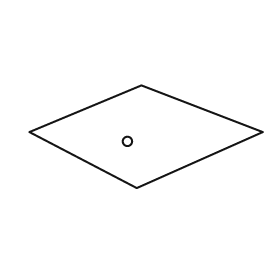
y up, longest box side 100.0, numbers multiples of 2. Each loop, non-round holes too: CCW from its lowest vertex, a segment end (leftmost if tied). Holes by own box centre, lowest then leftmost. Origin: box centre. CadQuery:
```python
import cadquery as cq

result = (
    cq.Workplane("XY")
    .moveTo(-4.0, -22.0)
    .lineTo(50.0, 2.0)
    .lineTo(-2.0, 22.0)
    .lineTo(-50.0, 2.0)
    .close()
    .moveTo(-8.0, -2.0)
    .circle(2.0)
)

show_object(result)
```